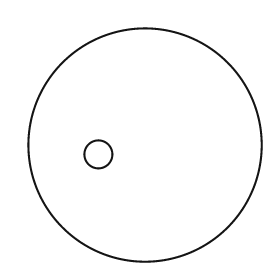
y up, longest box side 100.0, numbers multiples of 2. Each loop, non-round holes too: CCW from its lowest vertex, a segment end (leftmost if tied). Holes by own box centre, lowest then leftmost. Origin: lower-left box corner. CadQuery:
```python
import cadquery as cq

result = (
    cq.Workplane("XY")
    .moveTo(50.0, 50.0)
    .circle(50.0)
    .moveTo(30.0, 46.0)
    .circle(6.0)
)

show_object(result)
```